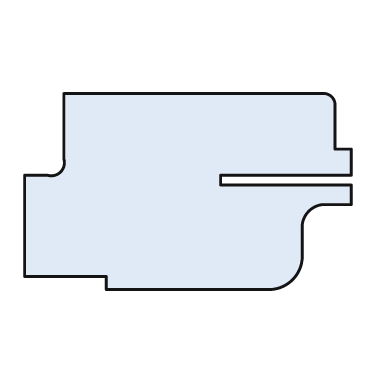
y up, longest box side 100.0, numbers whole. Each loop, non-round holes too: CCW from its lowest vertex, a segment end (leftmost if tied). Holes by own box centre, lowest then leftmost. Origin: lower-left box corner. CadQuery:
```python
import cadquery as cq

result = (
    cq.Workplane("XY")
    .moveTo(25.0, 0.0)
    .lineTo(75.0, 0.0)
    .threePointArc((82.0, 3.0), (85.0, 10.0))
    .lineTo(85.0, 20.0)
    .threePointArc((87.0, 24.0), (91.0, 26.0))
    .lineTo(100.0, 26.0)
    .lineTo(100.0, 32.0)
    .lineTo(60.0, 32.0)
    .lineTo(60.0, 35.0)
    .lineTo(100.0, 35.0)
    .lineTo(100.0, 43.0)
    .lineTo(95.0, 43.0)
    .lineTo(95.0, 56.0)
    .threePointArc((94.0, 59.0), (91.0, 60.0))
    .lineTo(12.0, 60.0)
    .lineTo(12.0, 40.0)
    .threePointArc((11.0, 36.0), (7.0, 35.0))
    .lineTo(0.0, 35.0)
    .lineTo(0.0, 4.0)
    .lineTo(25.0, 4.0)
    .close()
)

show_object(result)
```